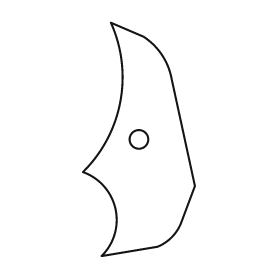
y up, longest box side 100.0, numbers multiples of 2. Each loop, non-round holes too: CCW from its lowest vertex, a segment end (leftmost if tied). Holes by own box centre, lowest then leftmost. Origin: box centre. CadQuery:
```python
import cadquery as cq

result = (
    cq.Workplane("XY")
    .moveTo(-16.0, -50.0)
    .lineTo(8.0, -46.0)
    .threePointArc((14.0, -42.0), (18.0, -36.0))
    .lineTo(24.0, -20.0)
    .lineTo(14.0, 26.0)
    .threePointArc((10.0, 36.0), (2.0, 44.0))
    .lineTo(-12.0, 50.0)
    .threePointArc((-8.0, 16.0), (-24.0, -14.0))
    .threePointArc((-10.0, -30.0), (-16.0, -50.0))
    .close()
    .moveTo(0.0, 0.0)
    .circle(4.0)
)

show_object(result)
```